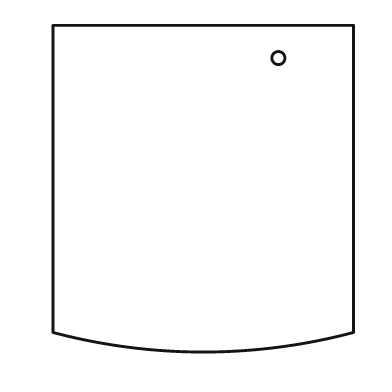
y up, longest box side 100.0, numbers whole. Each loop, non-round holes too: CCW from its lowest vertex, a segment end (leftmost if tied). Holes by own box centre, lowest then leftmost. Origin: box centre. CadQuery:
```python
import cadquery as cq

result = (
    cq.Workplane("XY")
    .moveTo(-46.0, -44.0)
    .threePointArc((0.0, -50.0), (46.0, -44.0))
    .lineTo(46.0, 50.0)
    .lineTo(-46.0, 50.0)
    .close()
    .moveTo(23.0, 40.0)
    .circle(2.0)
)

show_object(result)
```